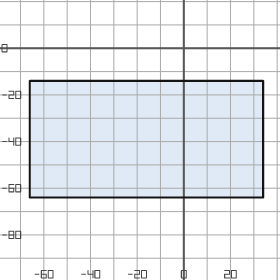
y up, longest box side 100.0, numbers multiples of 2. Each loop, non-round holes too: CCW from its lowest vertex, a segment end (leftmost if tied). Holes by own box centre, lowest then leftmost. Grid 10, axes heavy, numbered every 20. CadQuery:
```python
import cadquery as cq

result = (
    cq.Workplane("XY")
    .moveTo(-66.0, -64.0)
    .lineTo(34.0, -64.0)
    .lineTo(34.0, -14.0)
    .lineTo(-66.0, -14.0)
    .close()
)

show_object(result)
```